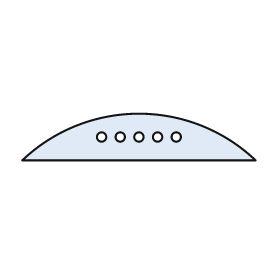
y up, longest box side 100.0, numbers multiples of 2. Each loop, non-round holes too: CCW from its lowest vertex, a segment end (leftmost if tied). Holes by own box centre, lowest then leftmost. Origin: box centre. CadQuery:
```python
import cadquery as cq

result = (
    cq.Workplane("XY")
    .moveTo(-50.0, -10.0)
    .lineTo(50.0, -10.0)
    .threePointArc((0.0, 10.0), (-50.0, -10.0))
    .close()
    .moveTo(-16.0, 0.0)
    .circle(2.0)
    .moveTo(-8.0, 0.0)
    .circle(2.0)
    .moveTo(0.0, 0.0)
    .circle(2.0)
    .moveTo(8.0, 0.0)
    .circle(2.0)
    .moveTo(16.0, 0.0)
    .circle(2.0)
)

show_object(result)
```